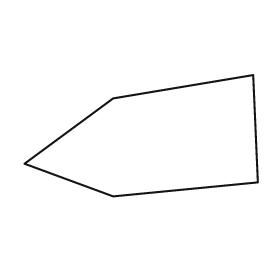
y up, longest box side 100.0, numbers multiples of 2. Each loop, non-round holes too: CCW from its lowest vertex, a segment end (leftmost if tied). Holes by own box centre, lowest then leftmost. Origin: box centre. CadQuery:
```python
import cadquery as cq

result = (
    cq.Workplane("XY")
    .moveTo(-12.0, -26.0)
    .lineTo(50.0, -20.0)
    .lineTo(48.0, 26.0)
    .lineTo(-12.0, 16.0)
    .lineTo(-50.0, -12.0)
    .close()
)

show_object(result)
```